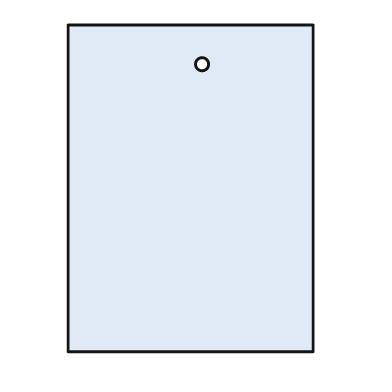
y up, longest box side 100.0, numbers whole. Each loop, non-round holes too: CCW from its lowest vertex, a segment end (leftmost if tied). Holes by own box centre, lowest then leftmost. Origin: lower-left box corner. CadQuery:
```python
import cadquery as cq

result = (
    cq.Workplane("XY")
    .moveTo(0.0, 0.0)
    .lineTo(75.0, 0.0)
    .lineTo(75.0, 100.0)
    .lineTo(0.0, 100.0)
    .close()
    .moveTo(41.0, 88.0)
    .circle(2.0)
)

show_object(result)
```